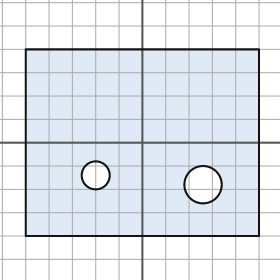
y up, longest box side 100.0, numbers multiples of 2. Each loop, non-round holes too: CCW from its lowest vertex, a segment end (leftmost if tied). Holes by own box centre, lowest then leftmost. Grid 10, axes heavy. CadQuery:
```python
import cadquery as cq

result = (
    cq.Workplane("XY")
    .moveTo(-50.0, -40.0)
    .lineTo(50.0, -40.0)
    .lineTo(50.0, 40.0)
    .lineTo(-50.0, 40.0)
    .close()
    .moveTo(26.0, -18.0)
    .circle(8.0)
    .moveTo(-20.0, -14.0)
    .circle(6.0)
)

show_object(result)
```